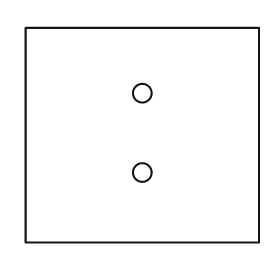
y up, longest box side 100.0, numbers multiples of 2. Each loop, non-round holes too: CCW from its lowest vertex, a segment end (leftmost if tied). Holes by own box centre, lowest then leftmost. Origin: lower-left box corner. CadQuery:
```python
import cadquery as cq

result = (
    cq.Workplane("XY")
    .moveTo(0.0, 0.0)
    .lineTo(100.0, 0.0)
    .lineTo(100.0, 92.0)
    .lineTo(0.0, 92.0)
    .close()
    .moveTo(50.0, 30.0)
    .circle(4.0)
    .moveTo(50.0, 64.0)
    .circle(4.0)
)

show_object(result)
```